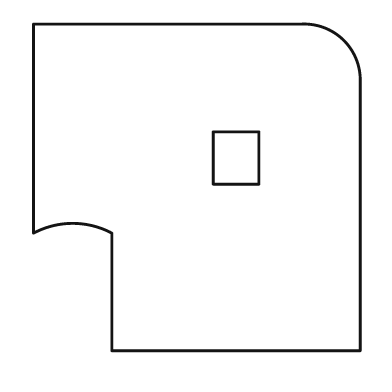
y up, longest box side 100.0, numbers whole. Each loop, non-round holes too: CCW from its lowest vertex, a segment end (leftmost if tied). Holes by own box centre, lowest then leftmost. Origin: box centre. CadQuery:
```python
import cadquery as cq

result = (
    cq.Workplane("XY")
    .moveTo(-26.0, -50.0)
    .lineTo(50.0, -50.0)
    .lineTo(50.0, 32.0)
    .threePointArc((45.0, 45.0), (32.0, 50.0))
    .lineTo(-50.0, 50.0)
    .lineTo(-50.0, -14.0)
    .threePointArc((-38.0, -11.0), (-26.0, -14.0))
    .close()
    .moveTo(5.0, 1.0)
    .lineTo(19.0, 1.0)
    .lineTo(19.0, 17.0)
    .lineTo(5.0, 17.0)
    .close()
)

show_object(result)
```